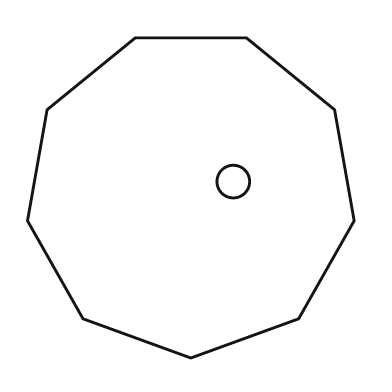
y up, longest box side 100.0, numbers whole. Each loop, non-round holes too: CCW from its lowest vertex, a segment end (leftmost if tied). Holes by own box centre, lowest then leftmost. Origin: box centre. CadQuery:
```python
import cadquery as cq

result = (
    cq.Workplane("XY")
    .moveTo(0.0, -49.0)
    .lineTo(33.0, -37.0)
    .lineTo(50.0, -7.0)
    .lineTo(44.0, 27.0)
    .lineTo(17.0, 49.0)
    .lineTo(-17.0, 49.0)
    .lineTo(-44.0, 27.0)
    .lineTo(-50.0, -7.0)
    .lineTo(-33.0, -37.0)
    .close()
    .moveTo(13.0, 5.0)
    .circle(5.0)
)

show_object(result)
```